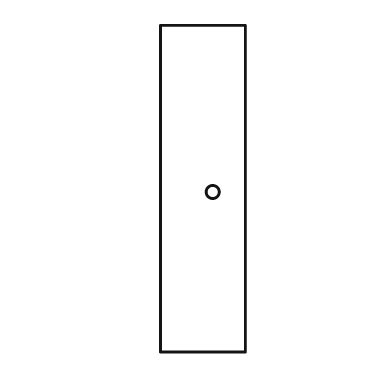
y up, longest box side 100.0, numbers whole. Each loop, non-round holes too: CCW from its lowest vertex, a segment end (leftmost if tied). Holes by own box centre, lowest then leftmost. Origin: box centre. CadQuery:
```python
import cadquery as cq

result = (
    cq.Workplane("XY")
    .moveTo(-13.0, -50.0)
    .lineTo(13.0, -50.0)
    .lineTo(13.0, 50.0)
    .lineTo(-13.0, 50.0)
    .close()
    .moveTo(3.0, -1.0)
    .circle(2.0)
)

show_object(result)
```